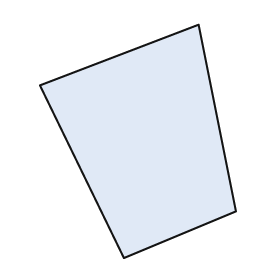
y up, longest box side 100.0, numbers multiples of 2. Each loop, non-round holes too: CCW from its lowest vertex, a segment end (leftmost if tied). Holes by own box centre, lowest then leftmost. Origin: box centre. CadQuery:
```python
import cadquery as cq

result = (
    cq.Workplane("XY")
    .moveTo(-6.0, -50.0)
    .lineTo(42.0, -30.0)
    .lineTo(26.0, 50.0)
    .lineTo(-42.0, 24.0)
    .close()
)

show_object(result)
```